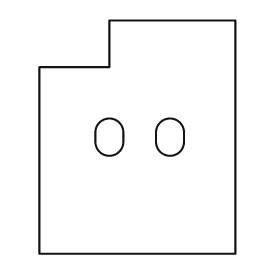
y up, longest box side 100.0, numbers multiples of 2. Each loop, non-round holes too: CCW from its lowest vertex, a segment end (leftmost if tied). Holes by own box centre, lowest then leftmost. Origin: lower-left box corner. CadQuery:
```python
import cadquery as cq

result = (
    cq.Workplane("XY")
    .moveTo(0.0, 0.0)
    .lineTo(84.0, 0.0)
    .lineTo(84.0, 100.0)
    .lineTo(30.0, 100.0)
    .lineTo(30.0, 80.0)
    .lineTo(0.0, 80.0)
    .close()
    .moveTo(24.0, 48.0)
    .threePointArc((30.0, 42.0), (36.0, 48.0))
    .lineTo(36.0, 52.0)
    .threePointArc((30.0, 58.0), (24.0, 52.0))
    .close()
    .moveTo(50.0, 48.0)
    .threePointArc((56.0, 42.0), (62.0, 48.0))
    .lineTo(62.0, 52.0)
    .threePointArc((56.0, 58.0), (50.0, 52.0))
    .close()
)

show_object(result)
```